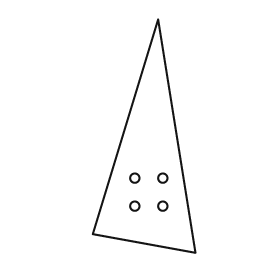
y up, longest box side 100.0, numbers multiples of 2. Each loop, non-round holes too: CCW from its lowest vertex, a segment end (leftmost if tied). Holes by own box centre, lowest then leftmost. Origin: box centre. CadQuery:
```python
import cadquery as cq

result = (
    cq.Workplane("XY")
    .moveTo(22.0, -50.0)
    .lineTo(6.0, 50.0)
    .lineTo(-22.0, -42.0)
    .close()
    .moveTo(-4.0, -30.0)
    .circle(2.0)
    .moveTo(8.0, -30.0)
    .circle(2.0)
    .moveTo(-4.0, -18.0)
    .circle(2.0)
    .moveTo(8.0, -18.0)
    .circle(2.0)
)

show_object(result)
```